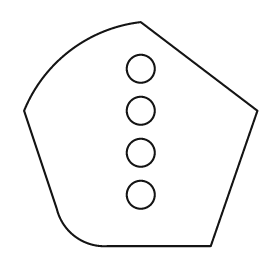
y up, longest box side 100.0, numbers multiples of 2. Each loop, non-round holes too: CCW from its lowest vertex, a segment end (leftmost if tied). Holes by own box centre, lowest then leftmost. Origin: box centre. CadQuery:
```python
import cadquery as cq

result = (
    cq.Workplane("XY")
    .moveTo(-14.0, -48.0)
    .lineTo(30.0, -48.0)
    .lineTo(50.0, 10.0)
    .lineTo(0.0, 48.0)
    .threePointArc((-30.0, 36.0), (-50.0, 10.0))
    .lineTo(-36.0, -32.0)
    .threePointArc((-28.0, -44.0), (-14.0, -48.0))
    .close()
    .moveTo(0.0, -26.0)
    .circle(6.0)
    .moveTo(0.0, -8.0)
    .circle(6.0)
    .moveTo(0.0, 10.0)
    .circle(6.0)
    .moveTo(0.0, 28.0)
    .circle(6.0)
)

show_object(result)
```